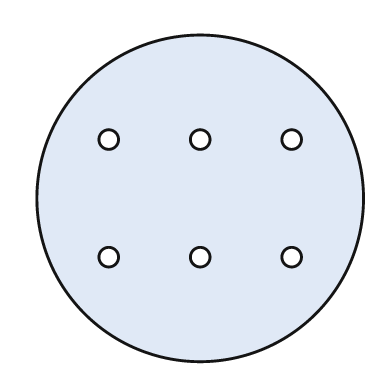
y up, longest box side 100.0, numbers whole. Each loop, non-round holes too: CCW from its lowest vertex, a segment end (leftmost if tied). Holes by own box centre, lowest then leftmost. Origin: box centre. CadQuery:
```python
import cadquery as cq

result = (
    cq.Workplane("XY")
    .moveTo(0.0, 0.0)
    .circle(50.0)
    .moveTo(-28.0, -18.0)
    .circle(3.0)
    .moveTo(0.0, -18.0)
    .circle(3.0)
    .moveTo(28.0, -18.0)
    .circle(3.0)
    .moveTo(-28.0, 18.0)
    .circle(3.0)
    .moveTo(0.0, 18.0)
    .circle(3.0)
    .moveTo(28.0, 18.0)
    .circle(3.0)
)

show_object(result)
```